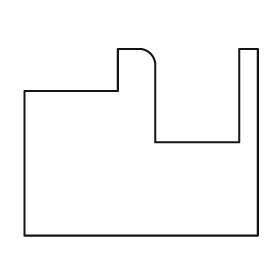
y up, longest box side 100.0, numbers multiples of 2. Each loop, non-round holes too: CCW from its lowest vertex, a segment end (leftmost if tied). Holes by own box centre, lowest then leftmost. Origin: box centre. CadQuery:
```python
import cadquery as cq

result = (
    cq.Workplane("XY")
    .moveTo(-50.0, -40.0)
    .lineTo(50.0, -40.0)
    .lineTo(50.0, 40.0)
    .lineTo(42.0, 40.0)
    .lineTo(42.0, 0.0)
    .lineTo(6.0, 0.0)
    .lineTo(6.0, 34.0)
    .threePointArc((4.0, 38.0), (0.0, 40.0))
    .lineTo(-10.0, 40.0)
    .lineTo(-10.0, 22.0)
    .lineTo(-50.0, 22.0)
    .close()
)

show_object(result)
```